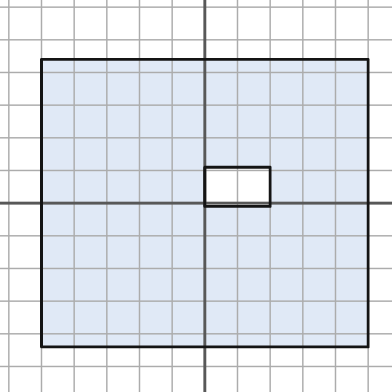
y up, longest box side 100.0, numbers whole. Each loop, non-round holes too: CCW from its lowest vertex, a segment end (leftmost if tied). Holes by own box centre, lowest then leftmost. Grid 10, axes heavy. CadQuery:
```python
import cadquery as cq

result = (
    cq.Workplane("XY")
    .moveTo(-50.0, -44.0)
    .lineTo(50.0, -44.0)
    .lineTo(50.0, 44.0)
    .lineTo(-50.0, 44.0)
    .close()
    .moveTo(0.0, -1.0)
    .lineTo(20.0, -1.0)
    .lineTo(20.0, 11.0)
    .lineTo(0.0, 11.0)
    .close()
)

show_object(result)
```